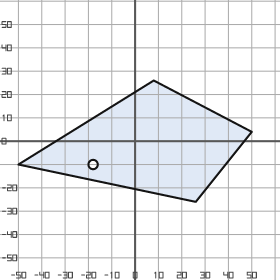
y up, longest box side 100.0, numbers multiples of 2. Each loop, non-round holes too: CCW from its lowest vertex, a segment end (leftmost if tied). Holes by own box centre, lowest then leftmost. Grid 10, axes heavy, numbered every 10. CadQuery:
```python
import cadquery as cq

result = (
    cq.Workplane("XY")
    .moveTo(26.0, -26.0)
    .lineTo(50.0, 4.0)
    .lineTo(8.0, 26.0)
    .lineTo(-50.0, -10.0)
    .close()
    .moveTo(-18.0, -10.0)
    .circle(2.0)
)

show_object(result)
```